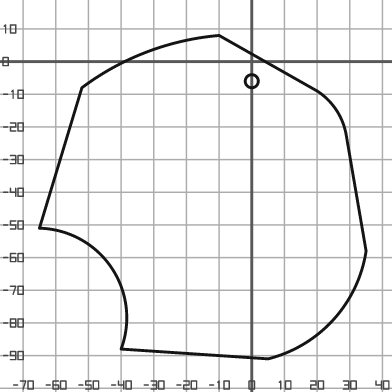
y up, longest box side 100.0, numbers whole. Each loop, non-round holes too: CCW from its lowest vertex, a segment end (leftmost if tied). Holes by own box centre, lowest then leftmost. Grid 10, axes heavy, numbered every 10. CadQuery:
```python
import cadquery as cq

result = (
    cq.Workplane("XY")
    .moveTo(5.0, -91.0)
    .threePointArc((25.0, -79.0), (35.0, -58.0))
    .lineTo(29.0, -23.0)
    .threePointArc((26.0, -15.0), (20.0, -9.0))
    .lineTo(-10.0, 8.0)
    .threePointArc((-32.0, 3.0), (-52.0, -8.0))
    .lineTo(-65.0, -51.0)
    .threePointArc((-43.0, -63.0), (-40.0, -88.0))
    .close()
    .moveTo(0.0, -6.0)
    .circle(2.0)
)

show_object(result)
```